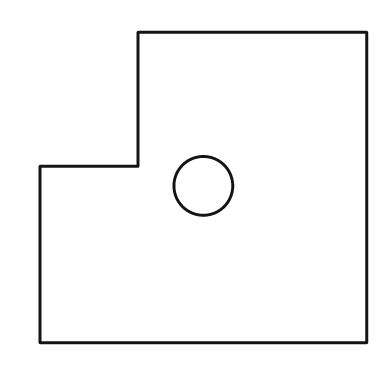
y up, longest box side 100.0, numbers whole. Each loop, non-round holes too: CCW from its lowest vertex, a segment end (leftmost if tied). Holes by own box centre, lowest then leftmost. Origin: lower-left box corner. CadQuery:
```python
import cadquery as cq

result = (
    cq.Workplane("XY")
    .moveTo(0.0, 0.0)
    .lineTo(100.0, 0.0)
    .lineTo(100.0, 95.0)
    .lineTo(30.0, 95.0)
    .lineTo(30.0, 54.0)
    .lineTo(0.0, 54.0)
    .close()
    .moveTo(50.0, 48.0)
    .circle(9.0)
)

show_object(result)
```